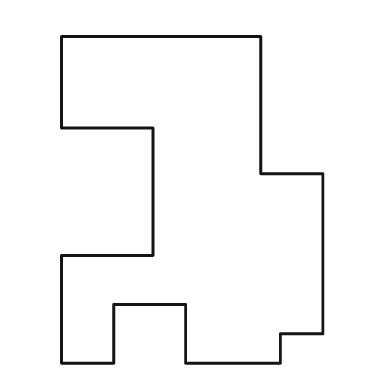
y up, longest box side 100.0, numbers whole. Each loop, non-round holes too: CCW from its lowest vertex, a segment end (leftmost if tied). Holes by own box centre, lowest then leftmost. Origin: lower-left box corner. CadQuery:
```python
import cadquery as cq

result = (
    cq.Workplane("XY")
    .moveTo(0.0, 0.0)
    .lineTo(16.0, 0.0)
    .lineTo(16.0, 18.0)
    .lineTo(38.0, 18.0)
    .lineTo(38.0, 0.0)
    .lineTo(67.0, 0.0)
    .lineTo(67.0, 9.0)
    .lineTo(80.0, 9.0)
    .lineTo(80.0, 58.0)
    .lineTo(61.0, 58.0)
    .lineTo(61.0, 100.0)
    .lineTo(0.0, 100.0)
    .lineTo(0.0, 72.0)
    .lineTo(28.0, 72.0)
    .lineTo(28.0, 33.0)
    .lineTo(0.0, 33.0)
    .close()
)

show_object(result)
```